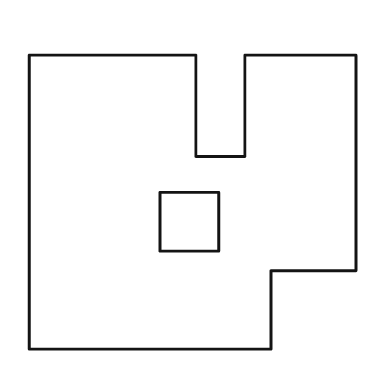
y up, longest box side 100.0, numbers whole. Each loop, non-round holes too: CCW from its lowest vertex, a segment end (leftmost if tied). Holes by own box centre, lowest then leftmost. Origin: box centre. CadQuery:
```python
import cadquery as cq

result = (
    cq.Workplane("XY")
    .moveTo(-50.0, -45.0)
    .lineTo(24.0, -45.0)
    .lineTo(24.0, -21.0)
    .lineTo(50.0, -21.0)
    .lineTo(50.0, 45.0)
    .lineTo(16.0, 45.0)
    .lineTo(16.0, 14.0)
    .lineTo(1.0, 14.0)
    .lineTo(1.0, 45.0)
    .lineTo(-50.0, 45.0)
    .close()
    .moveTo(-10.0, -15.0)
    .lineTo(8.0, -15.0)
    .lineTo(8.0, 3.0)
    .lineTo(-10.0, 3.0)
    .close()
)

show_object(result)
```